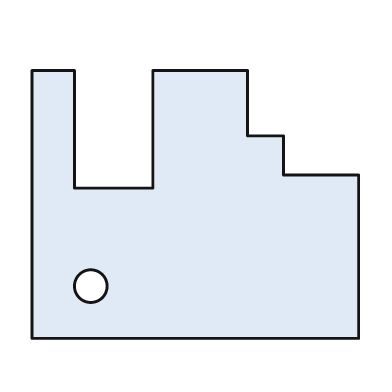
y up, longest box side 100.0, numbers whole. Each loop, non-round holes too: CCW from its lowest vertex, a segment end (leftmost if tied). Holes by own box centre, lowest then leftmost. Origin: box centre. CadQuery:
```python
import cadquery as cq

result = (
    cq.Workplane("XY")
    .moveTo(-50.0, -41.0)
    .lineTo(50.0, -41.0)
    .lineTo(50.0, 9.0)
    .lineTo(27.0, 9.0)
    .lineTo(27.0, 21.0)
    .lineTo(16.0, 21.0)
    .lineTo(16.0, 41.0)
    .lineTo(-13.0, 41.0)
    .lineTo(-13.0, 5.0)
    .lineTo(-37.0, 5.0)
    .lineTo(-37.0, 41.0)
    .lineTo(-50.0, 41.0)
    .close()
    .moveTo(-32.0, -25.0)
    .circle(5.0)
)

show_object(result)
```